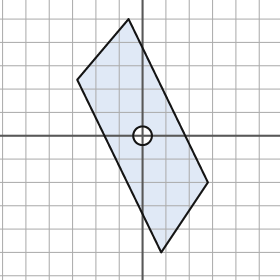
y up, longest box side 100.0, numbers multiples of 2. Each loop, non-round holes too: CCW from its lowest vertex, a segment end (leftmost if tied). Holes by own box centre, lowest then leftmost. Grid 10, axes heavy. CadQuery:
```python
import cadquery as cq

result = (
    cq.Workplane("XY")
    .moveTo(8.0, -50.0)
    .lineTo(28.0, -20.0)
    .lineTo(-6.0, 50.0)
    .lineTo(-28.0, 24.0)
    .close()
    .moveTo(0.0, 0.0)
    .circle(4.0)
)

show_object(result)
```